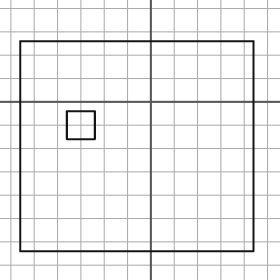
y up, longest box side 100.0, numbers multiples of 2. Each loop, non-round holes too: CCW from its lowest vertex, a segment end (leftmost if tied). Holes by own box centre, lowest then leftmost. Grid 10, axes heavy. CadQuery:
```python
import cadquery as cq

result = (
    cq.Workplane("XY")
    .moveTo(-56.0, -64.0)
    .lineTo(44.0, -64.0)
    .lineTo(44.0, 26.0)
    .lineTo(-56.0, 26.0)
    .close()
    .moveTo(-36.0, -16.0)
    .lineTo(-24.0, -16.0)
    .lineTo(-24.0, -4.0)
    .lineTo(-36.0, -4.0)
    .close()
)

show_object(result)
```